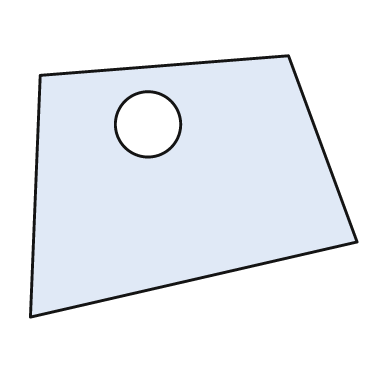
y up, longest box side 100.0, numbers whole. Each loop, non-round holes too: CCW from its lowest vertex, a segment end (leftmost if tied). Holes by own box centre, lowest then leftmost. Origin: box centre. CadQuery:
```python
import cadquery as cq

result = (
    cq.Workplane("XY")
    .moveTo(-50.0, -40.0)
    .lineTo(50.0, -17.0)
    .lineTo(29.0, 40.0)
    .lineTo(-47.0, 34.0)
    .close()
    .moveTo(-14.0, 19.0)
    .circle(10.0)
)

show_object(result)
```